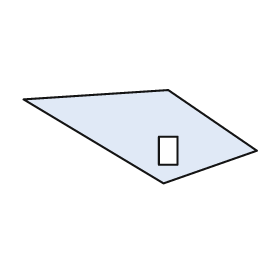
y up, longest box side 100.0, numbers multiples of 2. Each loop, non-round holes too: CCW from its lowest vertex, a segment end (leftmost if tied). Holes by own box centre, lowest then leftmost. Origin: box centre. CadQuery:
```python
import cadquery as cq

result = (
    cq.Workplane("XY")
    .moveTo(10.0, -20.0)
    .lineTo(50.0, -6.0)
    .lineTo(12.0, 20.0)
    .lineTo(-50.0, 16.0)
    .close()
    .moveTo(8.0, -12.0)
    .lineTo(16.0, -12.0)
    .lineTo(16.0, 0.0)
    .lineTo(8.0, 0.0)
    .close()
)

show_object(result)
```